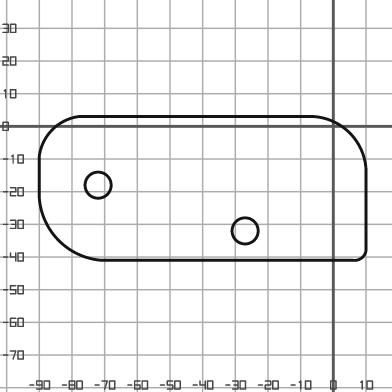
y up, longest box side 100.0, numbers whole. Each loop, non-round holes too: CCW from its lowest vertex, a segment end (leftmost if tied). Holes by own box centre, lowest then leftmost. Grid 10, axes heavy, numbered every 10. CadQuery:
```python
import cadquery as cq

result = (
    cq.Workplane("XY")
    .moveTo(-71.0, -41.0)
    .lineTo(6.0, -41.0)
    .threePointArc((9.0, -40.0), (10.0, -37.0))
    .lineTo(10.0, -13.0)
    .threePointArc((5.0, -2.0), (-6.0, 3.0))
    .lineTo(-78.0, 3.0)
    .threePointArc((-86.0, -1.0), (-90.0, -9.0))
    .lineTo(-90.0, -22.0)
    .threePointArc((-84.0, -35.0), (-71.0, -41.0))
    .close()
    .moveTo(-27.0, -32.0)
    .circle(4.0)
    .moveTo(-72.0, -18.0)
    .circle(4.0)
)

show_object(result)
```